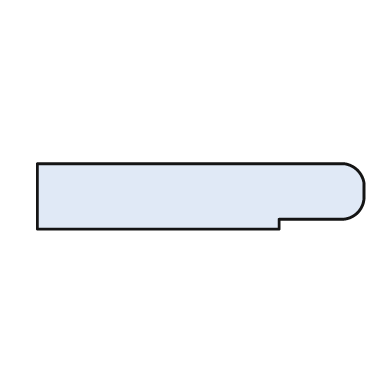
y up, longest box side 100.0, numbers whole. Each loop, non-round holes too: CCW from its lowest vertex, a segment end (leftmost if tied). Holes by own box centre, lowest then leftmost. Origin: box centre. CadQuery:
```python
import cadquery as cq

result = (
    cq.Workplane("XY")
    .moveTo(-50.0, -10.0)
    .lineTo(24.0, -10.0)
    .lineTo(24.0, -7.0)
    .lineTo(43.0, -7.0)
    .threePointArc((48.0, -5.0), (50.0, 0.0))
    .lineTo(50.0, 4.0)
    .threePointArc((48.0, 8.0), (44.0, 10.0))
    .lineTo(-50.0, 10.0)
    .close()
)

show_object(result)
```